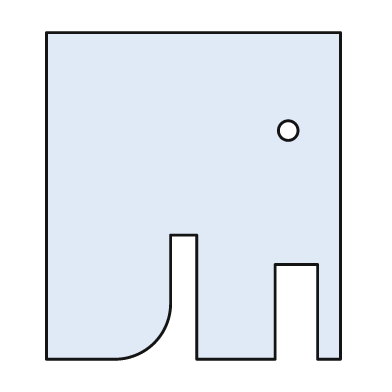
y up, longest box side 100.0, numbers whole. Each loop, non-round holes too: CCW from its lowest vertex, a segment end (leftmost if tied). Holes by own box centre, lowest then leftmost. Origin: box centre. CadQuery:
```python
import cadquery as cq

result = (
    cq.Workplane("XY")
    .moveTo(-45.0, -50.0)
    .lineTo(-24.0, -50.0)
    .threePointArc((-12.0, -45.0), (-7.0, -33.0))
    .lineTo(-7.0, -12.0)
    .lineTo(1.0, -12.0)
    .lineTo(1.0, -50.0)
    .lineTo(25.0, -50.0)
    .lineTo(25.0, -21.0)
    .lineTo(38.0, -21.0)
    .lineTo(38.0, -50.0)
    .lineTo(45.0, -50.0)
    .lineTo(45.0, 50.0)
    .lineTo(-45.0, 50.0)
    .close()
    .moveTo(29.0, 20.0)
    .circle(3.0)
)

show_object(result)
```